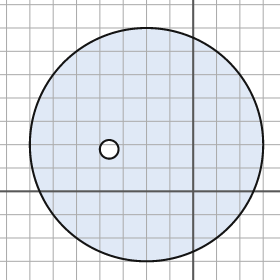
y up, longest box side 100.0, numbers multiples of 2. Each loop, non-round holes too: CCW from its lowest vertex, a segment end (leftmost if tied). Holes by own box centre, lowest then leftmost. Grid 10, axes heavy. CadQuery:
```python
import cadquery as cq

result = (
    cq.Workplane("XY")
    .moveTo(-20.0, 20.0)
    .circle(50.0)
    .moveTo(-36.0, 18.0)
    .circle(4.0)
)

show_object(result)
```